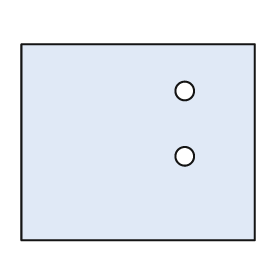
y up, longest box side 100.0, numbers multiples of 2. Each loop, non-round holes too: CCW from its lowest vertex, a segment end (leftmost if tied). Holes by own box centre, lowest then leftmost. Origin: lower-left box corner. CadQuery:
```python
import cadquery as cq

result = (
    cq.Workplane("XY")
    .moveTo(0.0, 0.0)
    .lineTo(100.0, 0.0)
    .lineTo(100.0, 84.0)
    .lineTo(0.0, 84.0)
    .close()
    .moveTo(70.0, 36.0)
    .circle(4.0)
    .moveTo(70.0, 64.0)
    .circle(4.0)
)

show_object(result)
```